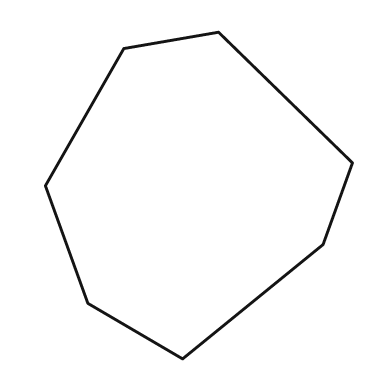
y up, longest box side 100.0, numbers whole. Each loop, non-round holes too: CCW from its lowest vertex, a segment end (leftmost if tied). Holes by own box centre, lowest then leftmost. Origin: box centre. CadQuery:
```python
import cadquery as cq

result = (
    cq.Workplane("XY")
    .moveTo(-5.0, -50.0)
    .lineTo(38.0, -15.0)
    .lineTo(47.0, 10.0)
    .lineTo(6.0, 50.0)
    .lineTo(-23.0, 45.0)
    .lineTo(-47.0, 3.0)
    .lineTo(-34.0, -33.0)
    .close()
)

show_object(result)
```